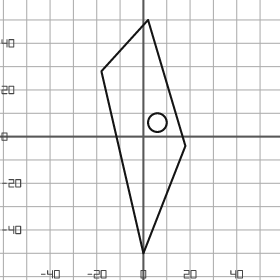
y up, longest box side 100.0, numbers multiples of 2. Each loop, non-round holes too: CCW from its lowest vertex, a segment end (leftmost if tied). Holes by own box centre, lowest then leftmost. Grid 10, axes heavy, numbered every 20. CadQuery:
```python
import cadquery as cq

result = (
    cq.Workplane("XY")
    .moveTo(0.0, -50.0)
    .lineTo(18.0, -4.0)
    .lineTo(2.0, 50.0)
    .lineTo(-18.0, 28.0)
    .close()
    .moveTo(6.0, 6.0)
    .circle(4.0)
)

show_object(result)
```